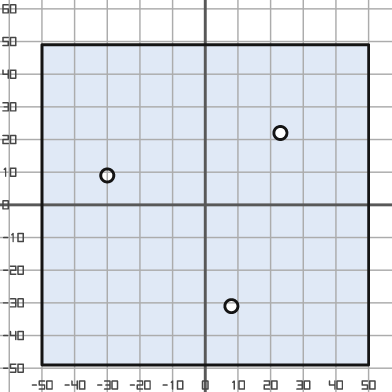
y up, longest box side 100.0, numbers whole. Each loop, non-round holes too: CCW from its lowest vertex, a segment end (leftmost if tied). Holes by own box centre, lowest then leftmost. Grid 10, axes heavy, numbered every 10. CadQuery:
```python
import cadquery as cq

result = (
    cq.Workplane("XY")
    .moveTo(-50.0, -49.0)
    .lineTo(50.0, -49.0)
    .lineTo(50.0, 49.0)
    .lineTo(-50.0, 49.0)
    .close()
    .moveTo(8.0, -31.0)
    .circle(2.0)
    .moveTo(-30.0, 9.0)
    .circle(2.0)
    .moveTo(23.0, 22.0)
    .circle(2.0)
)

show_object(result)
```